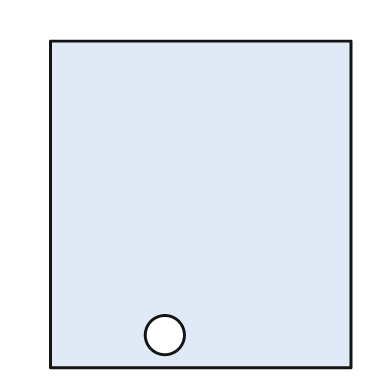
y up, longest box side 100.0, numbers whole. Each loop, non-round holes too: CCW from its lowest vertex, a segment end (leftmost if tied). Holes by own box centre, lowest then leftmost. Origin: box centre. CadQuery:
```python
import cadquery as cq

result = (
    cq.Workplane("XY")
    .moveTo(-46.0, -50.0)
    .lineTo(46.0, -50.0)
    .lineTo(46.0, 50.0)
    .lineTo(-46.0, 50.0)
    .close()
    .moveTo(-11.0, -40.0)
    .circle(6.0)
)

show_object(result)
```